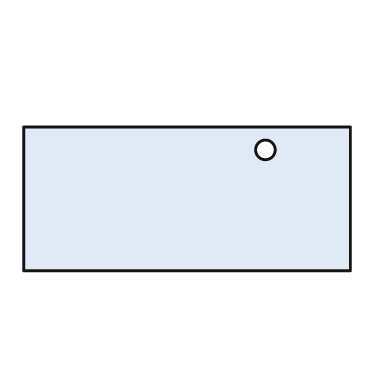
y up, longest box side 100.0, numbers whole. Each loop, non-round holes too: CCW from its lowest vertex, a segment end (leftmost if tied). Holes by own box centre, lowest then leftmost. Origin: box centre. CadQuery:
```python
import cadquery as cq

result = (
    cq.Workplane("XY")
    .moveTo(-50.0, -22.0)
    .lineTo(50.0, -22.0)
    .lineTo(50.0, 22.0)
    .lineTo(-50.0, 22.0)
    .close()
    .moveTo(24.0, 15.0)
    .circle(3.0)
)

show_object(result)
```